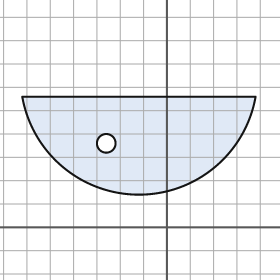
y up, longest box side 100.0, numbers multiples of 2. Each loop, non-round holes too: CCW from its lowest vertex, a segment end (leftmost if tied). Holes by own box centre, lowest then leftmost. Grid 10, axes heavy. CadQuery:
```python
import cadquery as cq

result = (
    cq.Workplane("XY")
    .moveTo(-62.0, 56.0)
    .threePointArc((-12.0, 14.0), (38.0, 56.0))
    .close()
    .moveTo(-26.0, 36.0)
    .circle(4.0)
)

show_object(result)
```